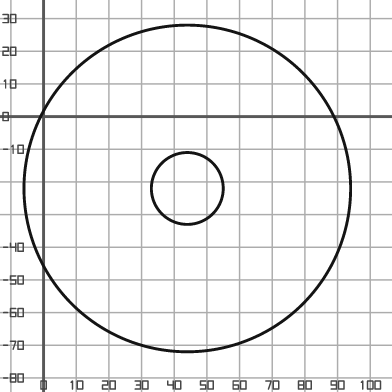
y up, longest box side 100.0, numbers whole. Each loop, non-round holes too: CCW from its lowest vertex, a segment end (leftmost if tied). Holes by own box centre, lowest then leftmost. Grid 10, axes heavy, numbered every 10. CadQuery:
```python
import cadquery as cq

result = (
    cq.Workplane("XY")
    .moveTo(44.0, -22.0)
    .circle(50.0)
    .moveTo(44.0, -22.0)
    .circle(11.0)
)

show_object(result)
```